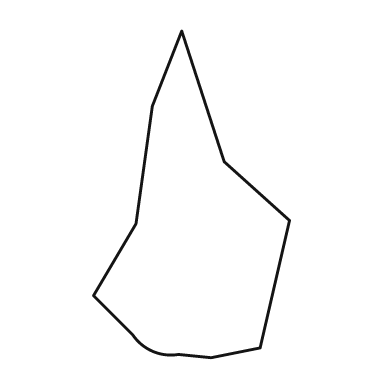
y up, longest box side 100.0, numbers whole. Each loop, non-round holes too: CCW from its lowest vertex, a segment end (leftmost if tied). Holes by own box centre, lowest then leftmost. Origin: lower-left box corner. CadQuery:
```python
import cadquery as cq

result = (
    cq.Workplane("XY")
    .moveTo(36.0, 0.0)
    .lineTo(51.0, 3.0)
    .lineTo(60.0, 42.0)
    .lineTo(40.0, 60.0)
    .lineTo(27.0, 100.0)
    .lineTo(18.0, 77.0)
    .lineTo(13.0, 41.0)
    .lineTo(0.0, 19.0)
    .lineTo(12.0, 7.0)
    .threePointArc((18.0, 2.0), (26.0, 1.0))
    .close()
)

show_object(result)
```